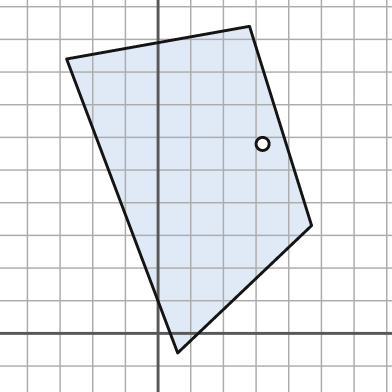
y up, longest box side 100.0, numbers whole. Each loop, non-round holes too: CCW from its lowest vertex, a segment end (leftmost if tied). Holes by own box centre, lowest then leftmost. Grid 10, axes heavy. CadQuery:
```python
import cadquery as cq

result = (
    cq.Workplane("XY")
    .moveTo(6.0, -6.0)
    .lineTo(47.0, 33.0)
    .lineTo(28.0, 94.0)
    .lineTo(-28.0, 84.0)
    .close()
    .moveTo(32.0, 58.0)
    .circle(2.0)
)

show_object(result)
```